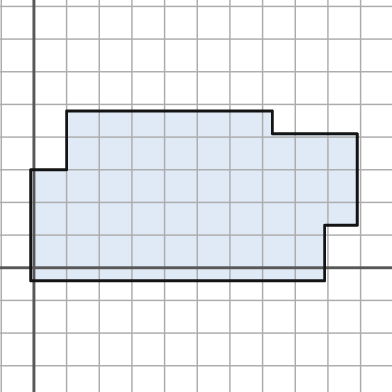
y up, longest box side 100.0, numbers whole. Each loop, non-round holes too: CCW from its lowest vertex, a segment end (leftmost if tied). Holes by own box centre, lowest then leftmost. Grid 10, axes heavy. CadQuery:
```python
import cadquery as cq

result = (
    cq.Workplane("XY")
    .moveTo(-1.0, -4.0)
    .lineTo(89.0, -4.0)
    .lineTo(89.0, 13.0)
    .lineTo(99.0, 13.0)
    .lineTo(99.0, 41.0)
    .lineTo(73.0, 41.0)
    .lineTo(73.0, 48.0)
    .lineTo(10.0, 48.0)
    .lineTo(10.0, 30.0)
    .lineTo(-1.0, 30.0)
    .close()
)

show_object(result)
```